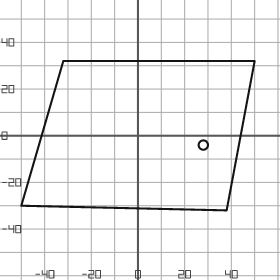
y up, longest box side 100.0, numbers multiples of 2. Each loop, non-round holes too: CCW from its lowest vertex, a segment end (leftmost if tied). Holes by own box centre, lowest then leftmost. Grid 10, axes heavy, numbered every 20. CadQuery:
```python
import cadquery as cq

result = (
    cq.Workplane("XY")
    .moveTo(38.0, -32.0)
    .lineTo(50.0, 32.0)
    .lineTo(-32.0, 32.0)
    .lineTo(-50.0, -30.0)
    .close()
    .moveTo(28.0, -4.0)
    .circle(2.0)
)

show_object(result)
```